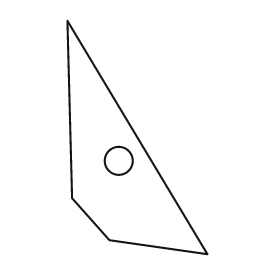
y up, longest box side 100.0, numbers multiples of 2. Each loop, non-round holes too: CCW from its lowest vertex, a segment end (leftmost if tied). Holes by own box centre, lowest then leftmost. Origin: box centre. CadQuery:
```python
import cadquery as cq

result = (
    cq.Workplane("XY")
    .moveTo(30.0, -50.0)
    .lineTo(-30.0, 50.0)
    .lineTo(-28.0, -26.0)
    .lineTo(-12.0, -44.0)
    .close()
    .moveTo(-8.0, -10.0)
    .circle(6.0)
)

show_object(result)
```